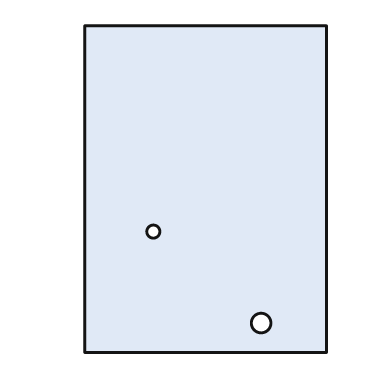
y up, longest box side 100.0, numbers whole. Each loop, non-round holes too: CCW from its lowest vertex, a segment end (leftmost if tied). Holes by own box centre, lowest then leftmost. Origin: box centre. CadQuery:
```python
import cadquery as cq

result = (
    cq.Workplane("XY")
    .moveTo(-37.0, -50.0)
    .lineTo(37.0, -50.0)
    .lineTo(37.0, 50.0)
    .lineTo(-37.0, 50.0)
    .close()
    .moveTo(17.0, -41.0)
    .circle(3.0)
    .moveTo(-16.0, -13.0)
    .circle(2.0)
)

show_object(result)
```